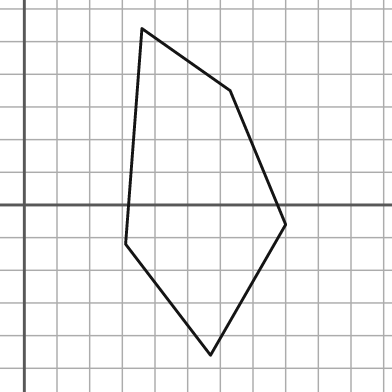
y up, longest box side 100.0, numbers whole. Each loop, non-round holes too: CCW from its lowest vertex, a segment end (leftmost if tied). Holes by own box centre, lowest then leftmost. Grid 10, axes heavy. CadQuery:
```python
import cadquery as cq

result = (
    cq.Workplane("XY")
    .moveTo(57.0, -46.0)
    .lineTo(80.0, -6.0)
    .lineTo(63.0, 35.0)
    .lineTo(36.0, 54.0)
    .lineTo(31.0, -12.0)
    .close()
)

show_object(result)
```